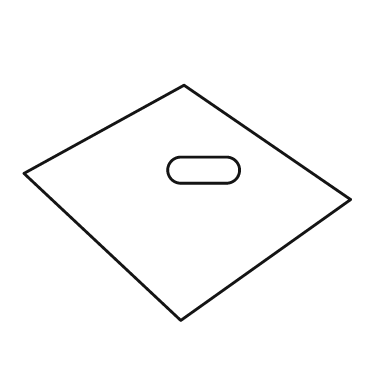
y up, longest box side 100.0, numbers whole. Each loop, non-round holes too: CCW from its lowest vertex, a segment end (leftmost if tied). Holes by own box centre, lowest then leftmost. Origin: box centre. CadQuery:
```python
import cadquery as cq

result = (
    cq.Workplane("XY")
    .moveTo(-2.0, -36.0)
    .lineTo(50.0, 1.0)
    .lineTo(-1.0, 36.0)
    .lineTo(-50.0, 9.0)
    .close()
    .moveTo(-2.0, 6.0)
    .lineTo(12.0, 6.0)
    .threePointArc((16.0, 10.0), (12.0, 14.0))
    .lineTo(-2.0, 14.0)
    .threePointArc((-6.0, 10.0), (-2.0, 6.0))
    .close()
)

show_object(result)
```